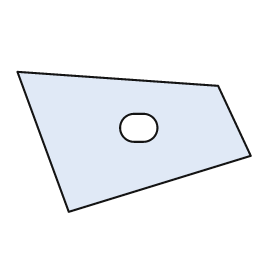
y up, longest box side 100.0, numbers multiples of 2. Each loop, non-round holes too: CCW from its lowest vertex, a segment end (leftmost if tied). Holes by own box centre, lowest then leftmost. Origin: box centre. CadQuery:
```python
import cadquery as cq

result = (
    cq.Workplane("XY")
    .moveTo(-28.0, -30.0)
    .lineTo(50.0, -6.0)
    .lineTo(36.0, 24.0)
    .lineTo(-50.0, 30.0)
    .close()
    .moveTo(0.0, 0.0)
    .lineTo(4.0, 0.0)
    .threePointArc((10.0, 6.0), (4.0, 12.0))
    .lineTo(0.0, 12.0)
    .threePointArc((-6.0, 6.0), (0.0, 0.0))
    .close()
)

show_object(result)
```